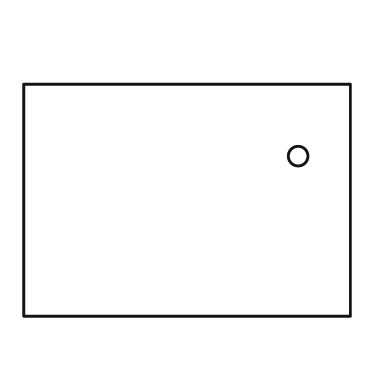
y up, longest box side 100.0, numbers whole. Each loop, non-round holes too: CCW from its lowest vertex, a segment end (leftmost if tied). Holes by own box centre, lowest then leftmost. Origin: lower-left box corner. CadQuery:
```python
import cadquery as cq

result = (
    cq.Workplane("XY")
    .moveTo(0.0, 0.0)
    .lineTo(100.0, 0.0)
    .lineTo(100.0, 71.0)
    .lineTo(0.0, 71.0)
    .close()
    .moveTo(84.0, 49.0)
    .circle(3.0)
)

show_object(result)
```